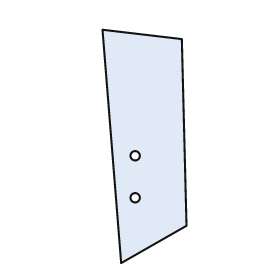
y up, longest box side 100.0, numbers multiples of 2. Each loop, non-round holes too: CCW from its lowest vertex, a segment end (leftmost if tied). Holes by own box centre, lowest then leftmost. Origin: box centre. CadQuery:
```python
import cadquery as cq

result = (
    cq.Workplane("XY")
    .moveTo(-10.0, -50.0)
    .lineTo(18.0, -34.0)
    .lineTo(16.0, 46.0)
    .lineTo(-18.0, 50.0)
    .close()
    .moveTo(-4.0, -22.0)
    .circle(2.0)
    .moveTo(-4.0, -4.0)
    .circle(2.0)
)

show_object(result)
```